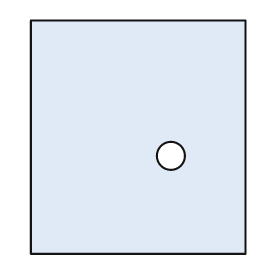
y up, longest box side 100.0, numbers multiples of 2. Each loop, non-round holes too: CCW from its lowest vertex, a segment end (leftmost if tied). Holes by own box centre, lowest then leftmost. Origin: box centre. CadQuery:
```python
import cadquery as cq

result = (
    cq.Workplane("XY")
    .moveTo(-46.0, -50.0)
    .lineTo(46.0, -50.0)
    .lineTo(46.0, 50.0)
    .lineTo(-46.0, 50.0)
    .close()
    .moveTo(14.0, -8.0)
    .circle(6.0)
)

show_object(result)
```